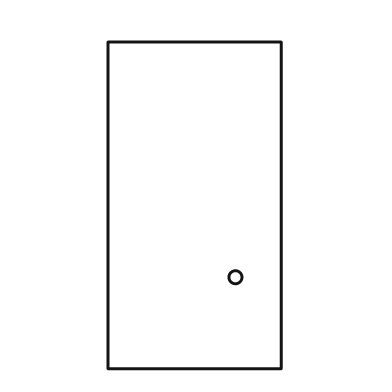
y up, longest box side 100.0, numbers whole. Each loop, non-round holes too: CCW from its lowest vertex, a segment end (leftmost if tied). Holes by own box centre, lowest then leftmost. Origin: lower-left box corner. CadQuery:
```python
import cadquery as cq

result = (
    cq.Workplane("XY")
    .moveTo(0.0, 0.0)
    .lineTo(53.0, 0.0)
    .lineTo(53.0, 100.0)
    .lineTo(0.0, 100.0)
    .close()
    .moveTo(39.0, 28.0)
    .circle(2.0)
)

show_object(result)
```